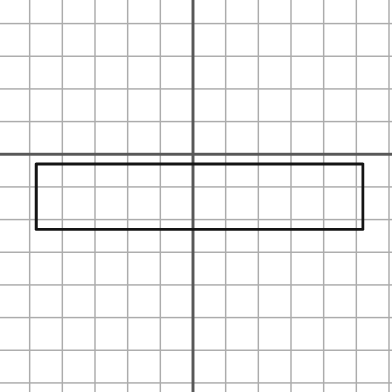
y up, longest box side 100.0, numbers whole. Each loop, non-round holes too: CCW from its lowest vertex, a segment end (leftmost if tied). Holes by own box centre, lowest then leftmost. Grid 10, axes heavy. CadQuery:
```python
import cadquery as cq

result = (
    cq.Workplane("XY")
    .moveTo(-48.0, -23.0)
    .lineTo(52.0, -23.0)
    .lineTo(52.0, -3.0)
    .lineTo(-48.0, -3.0)
    .close()
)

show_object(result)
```